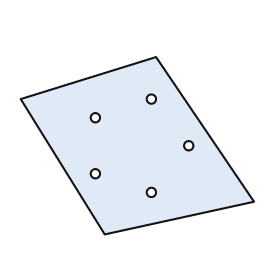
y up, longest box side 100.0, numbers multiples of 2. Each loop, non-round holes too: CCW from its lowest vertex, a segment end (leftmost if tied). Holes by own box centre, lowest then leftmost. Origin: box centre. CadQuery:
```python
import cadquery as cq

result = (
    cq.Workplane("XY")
    .moveTo(-14.0, -38.0)
    .lineTo(50.0, -24.0)
    .lineTo(8.0, 38.0)
    .lineTo(-50.0, 20.0)
    .close()
    .moveTo(6.0, -20.0)
    .circle(2.0)
    .moveTo(-18.0, -12.0)
    .circle(2.0)
    .moveTo(22.0, 0.0)
    .circle(2.0)
    .moveTo(-18.0, 12.0)
    .circle(2.0)
    .moveTo(6.0, 20.0)
    .circle(2.0)
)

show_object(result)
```